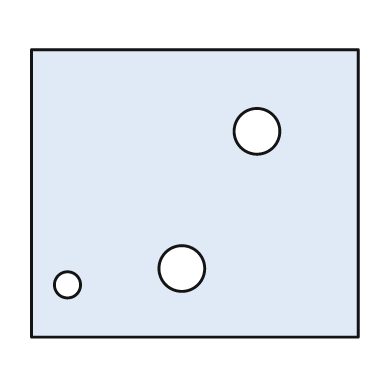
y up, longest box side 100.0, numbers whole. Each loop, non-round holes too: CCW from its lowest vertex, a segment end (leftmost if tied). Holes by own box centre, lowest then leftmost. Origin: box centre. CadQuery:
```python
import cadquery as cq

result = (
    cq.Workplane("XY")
    .moveTo(-50.0, -44.0)
    .lineTo(50.0, -44.0)
    .lineTo(50.0, 44.0)
    .lineTo(-50.0, 44.0)
    .close()
    .moveTo(-39.0, -28.0)
    .circle(4.0)
    .moveTo(-4.0, -23.0)
    .circle(7.0)
    .moveTo(19.0, 19.0)
    .circle(7.0)
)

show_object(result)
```